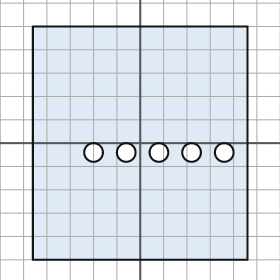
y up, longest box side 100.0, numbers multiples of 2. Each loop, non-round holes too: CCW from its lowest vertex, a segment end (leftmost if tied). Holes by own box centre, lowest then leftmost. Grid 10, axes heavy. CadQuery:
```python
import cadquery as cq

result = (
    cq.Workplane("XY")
    .moveTo(-46.0, -50.0)
    .lineTo(46.0, -50.0)
    .lineTo(46.0, 50.0)
    .lineTo(-46.0, 50.0)
    .close()
    .moveTo(-20.0, -4.0)
    .circle(4.0)
    .moveTo(-6.0, -4.0)
    .circle(4.0)
    .moveTo(8.0, -4.0)
    .circle(4.0)
    .moveTo(22.0, -4.0)
    .circle(4.0)
    .moveTo(36.0, -4.0)
    .circle(4.0)
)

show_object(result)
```